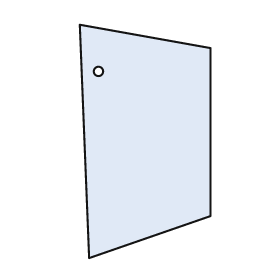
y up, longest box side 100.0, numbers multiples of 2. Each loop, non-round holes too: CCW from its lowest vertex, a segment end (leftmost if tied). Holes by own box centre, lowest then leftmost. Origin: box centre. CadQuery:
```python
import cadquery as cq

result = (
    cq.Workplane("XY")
    .moveTo(-24.0, -50.0)
    .lineTo(28.0, -32.0)
    .lineTo(28.0, 40.0)
    .lineTo(-28.0, 50.0)
    .close()
    .moveTo(-20.0, 30.0)
    .circle(2.0)
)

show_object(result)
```